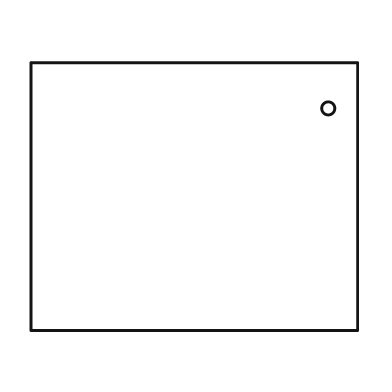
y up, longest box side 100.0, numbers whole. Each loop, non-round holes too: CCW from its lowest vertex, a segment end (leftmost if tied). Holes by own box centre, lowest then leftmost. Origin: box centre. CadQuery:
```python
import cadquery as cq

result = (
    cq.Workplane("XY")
    .moveTo(-50.0, -41.0)
    .lineTo(50.0, -41.0)
    .lineTo(50.0, 41.0)
    .lineTo(-50.0, 41.0)
    .close()
    .moveTo(41.0, 27.0)
    .circle(2.0)
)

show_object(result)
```